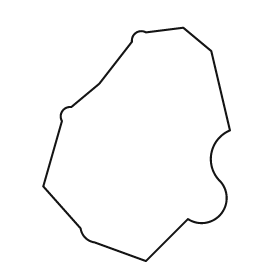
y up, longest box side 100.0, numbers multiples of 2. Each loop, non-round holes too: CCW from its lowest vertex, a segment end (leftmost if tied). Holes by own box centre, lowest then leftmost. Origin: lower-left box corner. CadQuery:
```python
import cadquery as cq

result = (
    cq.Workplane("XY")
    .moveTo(44.0, 0.0)
    .lineTo(62.0, 18.0)
    .threePointArc((76.0, 20.0), (76.0, 34.0))
    .threePointArc((72.0, 46.0), (80.0, 56.0))
    .lineTo(72.0, 90.0)
    .lineTo(60.0, 100.0)
    .lineTo(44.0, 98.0)
    .threePointArc((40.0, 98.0), (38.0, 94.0))
    .lineTo(24.0, 76.0)
    .lineTo(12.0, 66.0)
    .threePointArc((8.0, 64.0), (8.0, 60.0))
    .lineTo(0.0, 32.0)
    .lineTo(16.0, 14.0)
    .threePointArc((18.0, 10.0), (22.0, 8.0))
    .close()
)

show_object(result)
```